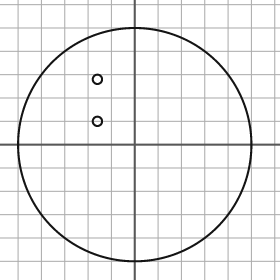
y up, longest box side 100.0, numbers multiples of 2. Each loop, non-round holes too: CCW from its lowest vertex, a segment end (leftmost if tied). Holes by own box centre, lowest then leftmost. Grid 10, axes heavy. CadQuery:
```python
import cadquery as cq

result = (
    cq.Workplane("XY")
    .moveTo(0.0, 0.0)
    .circle(50.0)
    .moveTo(-16.0, 10.0)
    .circle(2.0)
    .moveTo(-16.0, 28.0)
    .circle(2.0)
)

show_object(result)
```